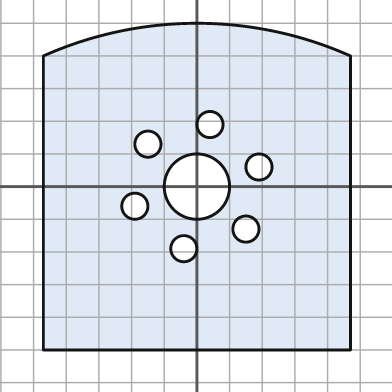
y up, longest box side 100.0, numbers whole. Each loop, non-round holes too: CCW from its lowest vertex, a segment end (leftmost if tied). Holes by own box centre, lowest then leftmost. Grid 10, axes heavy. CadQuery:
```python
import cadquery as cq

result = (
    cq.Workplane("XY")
    .moveTo(-47.0, -50.0)
    .lineTo(47.0, -50.0)
    .lineTo(47.0, 40.0)
    .threePointArc((0.0, 50.0), (-47.0, 40.0))
    .close()
    .moveTo(-4.0, -19.0)
    .circle(4.0)
    .moveTo(15.0, -13.0)
    .circle(4.0)
    .moveTo(-19.0, -6.0)
    .circle(4.0)
    .moveTo(0.0, 0.0)
    .circle(10.0)
    .moveTo(19.0, 6.0)
    .circle(4.0)
    .moveTo(-15.0, 13.0)
    .circle(4.0)
    .moveTo(4.0, 19.0)
    .circle(4.0)
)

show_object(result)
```